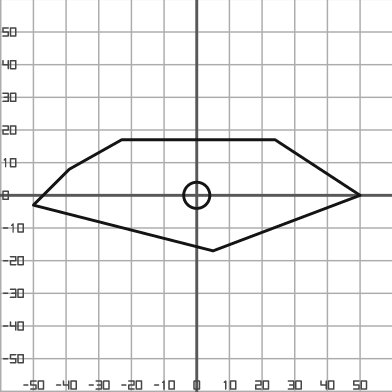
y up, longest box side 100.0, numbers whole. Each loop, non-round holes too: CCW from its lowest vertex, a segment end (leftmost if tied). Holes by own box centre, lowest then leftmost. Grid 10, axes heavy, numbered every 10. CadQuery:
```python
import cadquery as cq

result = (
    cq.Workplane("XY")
    .moveTo(5.0, -17.0)
    .lineTo(50.0, 0.0)
    .lineTo(24.0, 17.0)
    .lineTo(-23.0, 17.0)
    .lineTo(-39.0, 8.0)
    .lineTo(-50.0, -3.0)
    .close()
    .moveTo(0.0, 0.0)
    .circle(4.0)
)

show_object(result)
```